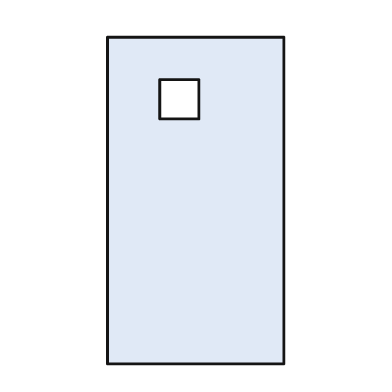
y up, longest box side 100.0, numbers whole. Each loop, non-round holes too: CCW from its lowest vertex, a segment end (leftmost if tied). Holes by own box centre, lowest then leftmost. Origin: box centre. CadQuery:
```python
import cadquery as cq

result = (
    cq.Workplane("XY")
    .moveTo(-27.0, -50.0)
    .lineTo(27.0, -50.0)
    .lineTo(27.0, 50.0)
    .lineTo(-27.0, 50.0)
    .close()
    .moveTo(-11.0, 25.0)
    .lineTo(1.0, 25.0)
    .lineTo(1.0, 37.0)
    .lineTo(-11.0, 37.0)
    .close()
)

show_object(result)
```